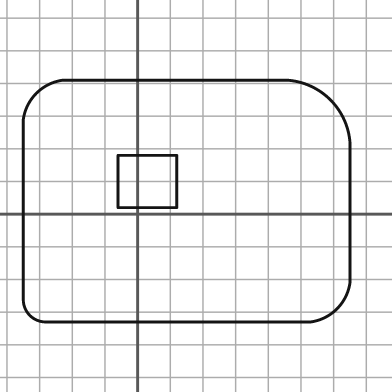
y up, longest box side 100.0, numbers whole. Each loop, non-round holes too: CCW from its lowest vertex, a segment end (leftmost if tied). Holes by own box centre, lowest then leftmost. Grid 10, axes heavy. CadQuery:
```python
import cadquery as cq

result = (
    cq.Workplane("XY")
    .moveTo(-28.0, -33.0)
    .lineTo(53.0, -33.0)
    .threePointArc((61.0, -29.0), (65.0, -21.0))
    .lineTo(65.0, 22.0)
    .threePointArc((59.0, 35.0), (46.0, 41.0))
    .lineTo(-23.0, 41.0)
    .threePointArc((-31.0, 37.0), (-35.0, 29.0))
    .lineTo(-35.0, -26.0)
    .threePointArc((-33.0, -31.0), (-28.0, -33.0))
    .close()
    .moveTo(-6.0, 2.0)
    .lineTo(12.0, 2.0)
    .lineTo(12.0, 18.0)
    .lineTo(-6.0, 18.0)
    .close()
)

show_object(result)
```